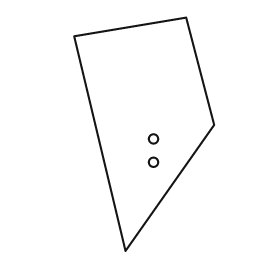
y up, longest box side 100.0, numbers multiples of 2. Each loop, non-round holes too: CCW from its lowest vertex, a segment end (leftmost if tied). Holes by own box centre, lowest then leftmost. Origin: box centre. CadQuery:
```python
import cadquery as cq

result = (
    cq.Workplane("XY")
    .moveTo(-8.0, -50.0)
    .lineTo(30.0, 4.0)
    .lineTo(18.0, 50.0)
    .lineTo(-30.0, 42.0)
    .close()
    .moveTo(4.0, -12.0)
    .circle(2.0)
    .moveTo(4.0, -2.0)
    .circle(2.0)
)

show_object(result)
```